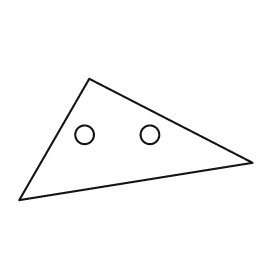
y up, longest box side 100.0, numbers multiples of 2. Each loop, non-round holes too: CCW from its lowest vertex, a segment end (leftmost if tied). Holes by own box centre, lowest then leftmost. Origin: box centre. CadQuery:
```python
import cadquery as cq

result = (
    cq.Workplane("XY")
    .moveTo(-50.0, -26.0)
    .lineTo(50.0, -10.0)
    .lineTo(-20.0, 26.0)
    .close()
    .moveTo(-22.0, 2.0)
    .circle(4.0)
    .moveTo(6.0, 2.0)
    .circle(4.0)
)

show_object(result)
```